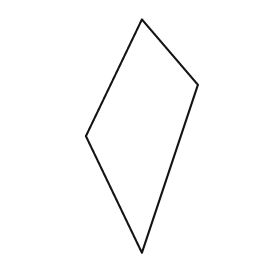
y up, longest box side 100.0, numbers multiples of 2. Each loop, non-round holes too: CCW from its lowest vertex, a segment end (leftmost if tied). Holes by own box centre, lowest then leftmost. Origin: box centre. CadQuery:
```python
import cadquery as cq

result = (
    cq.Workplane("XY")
    .moveTo(0.0, -50.0)
    .lineTo(24.0, 22.0)
    .lineTo(0.0, 50.0)
    .lineTo(-24.0, 0.0)
    .close()
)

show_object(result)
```